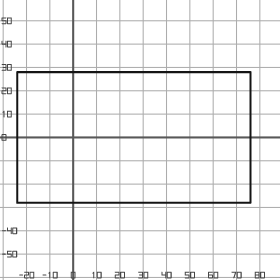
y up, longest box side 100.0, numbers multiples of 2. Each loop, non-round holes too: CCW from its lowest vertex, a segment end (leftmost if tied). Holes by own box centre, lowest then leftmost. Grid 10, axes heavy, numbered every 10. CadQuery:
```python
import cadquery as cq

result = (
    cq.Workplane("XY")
    .moveTo(-24.0, -28.0)
    .lineTo(76.0, -28.0)
    .lineTo(76.0, 28.0)
    .lineTo(-24.0, 28.0)
    .close()
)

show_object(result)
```